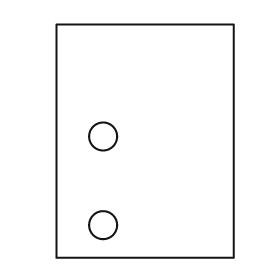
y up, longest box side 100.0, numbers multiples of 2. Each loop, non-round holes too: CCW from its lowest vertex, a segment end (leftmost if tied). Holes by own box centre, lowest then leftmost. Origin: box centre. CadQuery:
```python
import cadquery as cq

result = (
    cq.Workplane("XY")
    .moveTo(-38.0, -50.0)
    .lineTo(38.0, -50.0)
    .lineTo(38.0, 50.0)
    .lineTo(-38.0, 50.0)
    .close()
    .moveTo(-18.0, -36.0)
    .circle(6.0)
    .moveTo(-18.0, 2.0)
    .circle(6.0)
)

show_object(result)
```